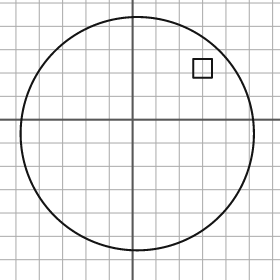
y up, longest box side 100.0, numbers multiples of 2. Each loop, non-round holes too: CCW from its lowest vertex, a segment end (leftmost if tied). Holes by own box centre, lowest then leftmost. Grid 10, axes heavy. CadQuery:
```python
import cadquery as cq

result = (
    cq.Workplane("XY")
    .moveTo(2.0, -6.0)
    .circle(50.0)
    .moveTo(26.0, 18.0)
    .lineTo(34.0, 18.0)
    .lineTo(34.0, 26.0)
    .lineTo(26.0, 26.0)
    .close()
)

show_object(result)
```